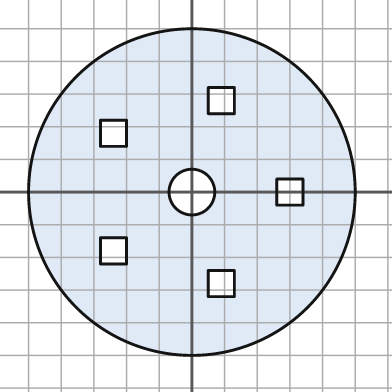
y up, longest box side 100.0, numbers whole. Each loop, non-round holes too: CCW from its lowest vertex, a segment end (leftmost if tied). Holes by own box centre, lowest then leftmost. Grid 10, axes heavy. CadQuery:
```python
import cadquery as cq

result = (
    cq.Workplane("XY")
    .moveTo(0.0, 0.0)
    .circle(50.0)
    .moveTo(5.0, -32.0)
    .lineTo(13.0, -32.0)
    .lineTo(13.0, -24.0)
    .lineTo(5.0, -24.0)
    .close()
    .moveTo(-28.0, -22.0)
    .lineTo(-20.0, -22.0)
    .lineTo(-20.0, -14.0)
    .lineTo(-28.0, -14.0)
    .close()
    .moveTo(0.0, 0.0)
    .circle(7.0)
    .moveTo(26.0, -4.0)
    .lineTo(34.0, -4.0)
    .lineTo(34.0, 4.0)
    .lineTo(26.0, 4.0)
    .close()
    .moveTo(-28.0, 14.0)
    .lineTo(-20.0, 14.0)
    .lineTo(-20.0, 22.0)
    .lineTo(-28.0, 22.0)
    .close()
    .moveTo(5.0, 24.0)
    .lineTo(13.0, 24.0)
    .lineTo(13.0, 32.0)
    .lineTo(5.0, 32.0)
    .close()
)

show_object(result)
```